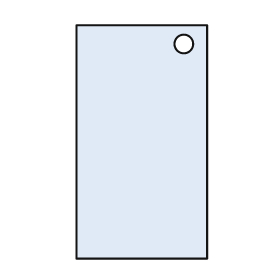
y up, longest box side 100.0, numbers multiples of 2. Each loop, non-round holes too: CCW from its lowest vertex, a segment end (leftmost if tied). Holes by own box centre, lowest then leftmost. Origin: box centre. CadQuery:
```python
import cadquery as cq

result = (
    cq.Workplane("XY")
    .moveTo(-28.0, -50.0)
    .lineTo(28.0, -50.0)
    .lineTo(28.0, 50.0)
    .lineTo(-28.0, 50.0)
    .close()
    .moveTo(18.0, 42.0)
    .circle(4.0)
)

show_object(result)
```